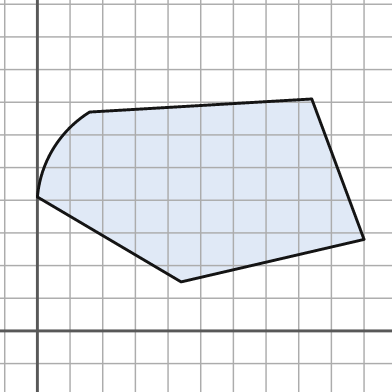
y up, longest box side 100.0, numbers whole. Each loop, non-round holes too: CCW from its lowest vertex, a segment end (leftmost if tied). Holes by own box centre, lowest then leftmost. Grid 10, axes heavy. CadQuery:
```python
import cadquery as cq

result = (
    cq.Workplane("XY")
    .moveTo(44.0, 15.0)
    .lineTo(100.0, 28.0)
    .lineTo(84.0, 71.0)
    .lineTo(16.0, 67.0)
    .threePointArc((5.0, 56.0), (0.0, 41.0))
    .close()
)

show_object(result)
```